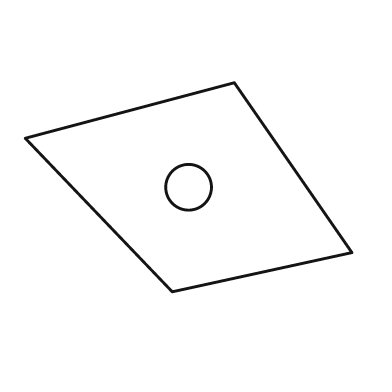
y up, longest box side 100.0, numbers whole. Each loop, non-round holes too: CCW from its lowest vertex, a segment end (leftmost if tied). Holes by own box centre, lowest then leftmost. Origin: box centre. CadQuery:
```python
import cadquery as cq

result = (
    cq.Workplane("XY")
    .moveTo(-5.0, -32.0)
    .lineTo(50.0, -20.0)
    .lineTo(14.0, 32.0)
    .lineTo(-50.0, 15.0)
    .close()
    .moveTo(0.0, 0.0)
    .circle(7.0)
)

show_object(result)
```